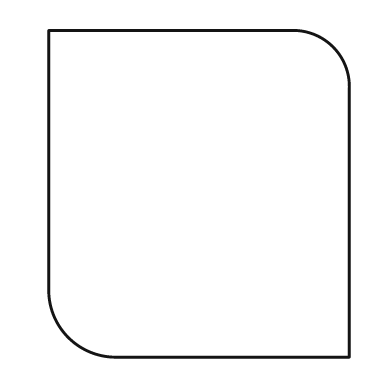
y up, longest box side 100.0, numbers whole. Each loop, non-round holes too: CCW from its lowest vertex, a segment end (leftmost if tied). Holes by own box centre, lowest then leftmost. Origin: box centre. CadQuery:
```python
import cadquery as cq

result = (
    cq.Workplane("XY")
    .moveTo(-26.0, -50.0)
    .lineTo(46.0, -50.0)
    .lineTo(46.0, 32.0)
    .threePointArc((41.0, 45.0), (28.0, 50.0))
    .lineTo(-46.0, 50.0)
    .lineTo(-46.0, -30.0)
    .threePointArc((-40.0, -44.0), (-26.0, -50.0))
    .close()
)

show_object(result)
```